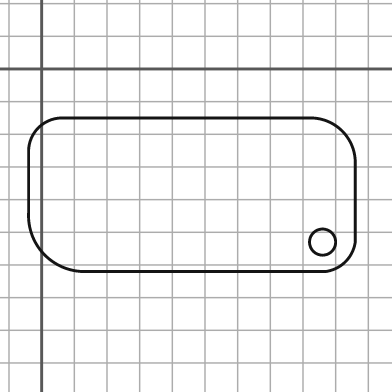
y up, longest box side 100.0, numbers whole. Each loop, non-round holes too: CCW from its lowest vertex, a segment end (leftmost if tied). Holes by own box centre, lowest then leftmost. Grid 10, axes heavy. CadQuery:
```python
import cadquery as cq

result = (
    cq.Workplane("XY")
    .moveTo(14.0, -62.0)
    .lineTo(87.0, -62.0)
    .threePointArc((93.0, -59.0), (96.0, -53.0))
    .lineTo(96.0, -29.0)
    .threePointArc((92.0, -19.0), (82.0, -15.0))
    .lineTo(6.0, -15.0)
    .threePointArc((-1.0, -18.0), (-4.0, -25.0))
    .lineTo(-4.0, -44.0)
    .threePointArc((1.0, -57.0), (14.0, -62.0))
    .close()
    .moveTo(86.0, -53.0)
    .circle(4.0)
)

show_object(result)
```